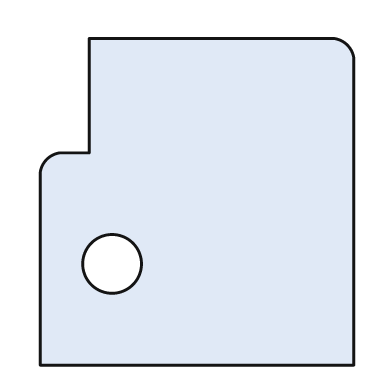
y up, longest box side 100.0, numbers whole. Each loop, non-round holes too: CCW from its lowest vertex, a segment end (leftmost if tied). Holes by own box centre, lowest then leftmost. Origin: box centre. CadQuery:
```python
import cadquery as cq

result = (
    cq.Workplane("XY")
    .moveTo(-48.0, -50.0)
    .lineTo(48.0, -50.0)
    .lineTo(48.0, 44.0)
    .threePointArc((46.0, 48.0), (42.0, 50.0))
    .lineTo(-33.0, 50.0)
    .lineTo(-33.0, 15.0)
    .lineTo(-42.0, 15.0)
    .threePointArc((-46.0, 13.0), (-48.0, 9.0))
    .close()
    .moveTo(-26.0, -19.0)
    .circle(9.0)
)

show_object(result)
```